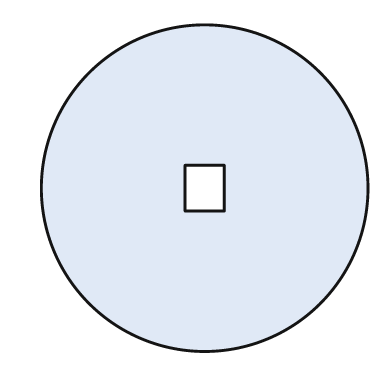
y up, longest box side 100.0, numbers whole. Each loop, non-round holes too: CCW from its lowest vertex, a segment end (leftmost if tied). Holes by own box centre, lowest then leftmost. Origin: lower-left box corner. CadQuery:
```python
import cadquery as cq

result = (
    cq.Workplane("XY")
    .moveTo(50.0, 50.0)
    .circle(50.0)
    .moveTo(44.0, 43.0)
    .lineTo(56.0, 43.0)
    .lineTo(56.0, 57.0)
    .lineTo(44.0, 57.0)
    .close()
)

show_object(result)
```